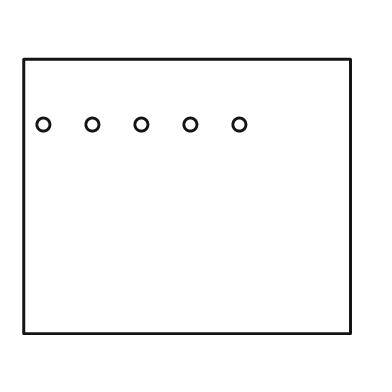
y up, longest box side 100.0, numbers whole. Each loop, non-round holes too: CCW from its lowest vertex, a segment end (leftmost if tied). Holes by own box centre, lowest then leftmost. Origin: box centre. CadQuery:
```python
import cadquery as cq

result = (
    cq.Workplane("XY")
    .moveTo(-50.0, -42.0)
    .lineTo(50.0, -42.0)
    .lineTo(50.0, 42.0)
    .lineTo(-50.0, 42.0)
    .close()
    .moveTo(-44.0, 22.0)
    .circle(2.0)
    .moveTo(-29.0, 22.0)
    .circle(2.0)
    .moveTo(-14.0, 22.0)
    .circle(2.0)
    .moveTo(1.0, 22.0)
    .circle(2.0)
    .moveTo(16.0, 22.0)
    .circle(2.0)
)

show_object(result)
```